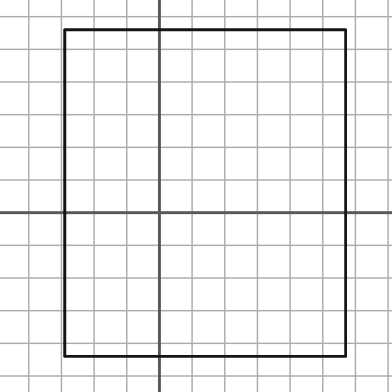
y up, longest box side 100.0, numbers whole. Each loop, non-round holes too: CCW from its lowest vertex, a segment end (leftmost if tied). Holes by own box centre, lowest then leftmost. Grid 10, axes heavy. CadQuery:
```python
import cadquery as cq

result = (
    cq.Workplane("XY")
    .moveTo(-29.0, -44.0)
    .lineTo(57.0, -44.0)
    .lineTo(57.0, 56.0)
    .lineTo(-29.0, 56.0)
    .close()
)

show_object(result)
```